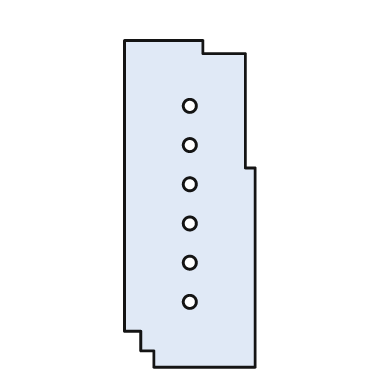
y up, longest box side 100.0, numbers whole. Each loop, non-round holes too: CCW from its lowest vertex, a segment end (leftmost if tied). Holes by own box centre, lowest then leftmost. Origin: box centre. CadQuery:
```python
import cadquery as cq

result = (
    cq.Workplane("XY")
    .moveTo(-11.0, -50.0)
    .lineTo(20.0, -50.0)
    .lineTo(20.0, 11.0)
    .lineTo(17.0, 11.0)
    .lineTo(17.0, 46.0)
    .lineTo(4.0, 46.0)
    .lineTo(4.0, 50.0)
    .lineTo(-20.0, 50.0)
    .lineTo(-20.0, -39.0)
    .lineTo(-15.0, -39.0)
    .lineTo(-15.0, -45.0)
    .lineTo(-11.0, -45.0)
    .close()
    .moveTo(0.0, -30.0)
    .circle(2.0)
    .moveTo(0.0, -18.0)
    .circle(2.0)
    .moveTo(0.0, -6.0)
    .circle(2.0)
    .moveTo(0.0, 6.0)
    .circle(2.0)
    .moveTo(0.0, 18.0)
    .circle(2.0)
    .moveTo(0.0, 30.0)
    .circle(2.0)
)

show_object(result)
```